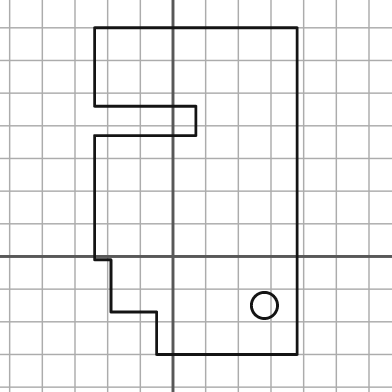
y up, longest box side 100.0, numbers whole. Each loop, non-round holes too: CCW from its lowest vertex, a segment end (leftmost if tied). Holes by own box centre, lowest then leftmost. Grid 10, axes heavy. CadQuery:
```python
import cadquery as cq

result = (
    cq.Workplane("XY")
    .moveTo(-5.0, -30.0)
    .lineTo(38.0, -30.0)
    .lineTo(38.0, 70.0)
    .lineTo(-24.0, 70.0)
    .lineTo(-24.0, 46.0)
    .lineTo(7.0, 46.0)
    .lineTo(7.0, 37.0)
    .lineTo(-24.0, 37.0)
    .lineTo(-24.0, -1.0)
    .lineTo(-19.0, -1.0)
    .lineTo(-19.0, -17.0)
    .lineTo(-5.0, -17.0)
    .close()
    .moveTo(28.0, -15.0)
    .circle(4.0)
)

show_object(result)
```